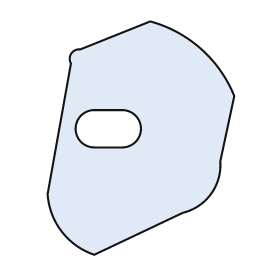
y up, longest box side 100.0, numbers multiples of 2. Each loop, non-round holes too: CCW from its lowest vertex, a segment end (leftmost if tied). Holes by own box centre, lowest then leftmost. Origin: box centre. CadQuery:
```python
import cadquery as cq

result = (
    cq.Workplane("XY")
    .moveTo(-20.0, -50.0)
    .lineTo(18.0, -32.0)
    .threePointArc((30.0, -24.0), (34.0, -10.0))
    .lineTo(40.0, 18.0)
    .threePointArc((26.0, 38.0), (4.0, 50.0))
    .lineTo(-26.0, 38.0)
    .threePointArc((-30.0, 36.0), (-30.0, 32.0))
    .lineTo(-40.0, -24.0)
    .threePointArc((-34.0, -40.0), (-20.0, -50.0))
    .close()
    .moveTo(-20.0, -4.0)
    .lineTo(-8.0, -4.0)
    .threePointArc((0.0, 4.0), (-8.0, 12.0))
    .lineTo(-20.0, 12.0)
    .threePointArc((-28.0, 4.0), (-20.0, -4.0))
    .close()
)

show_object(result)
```